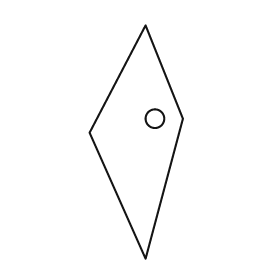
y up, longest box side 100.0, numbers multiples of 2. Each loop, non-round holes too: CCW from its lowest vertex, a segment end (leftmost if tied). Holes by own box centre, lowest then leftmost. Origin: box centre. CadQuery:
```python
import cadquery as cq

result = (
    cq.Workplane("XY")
    .moveTo(4.0, -50.0)
    .lineTo(20.0, 10.0)
    .lineTo(4.0, 50.0)
    .lineTo(-20.0, 4.0)
    .close()
    .moveTo(8.0, 10.0)
    .circle(4.0)
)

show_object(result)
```